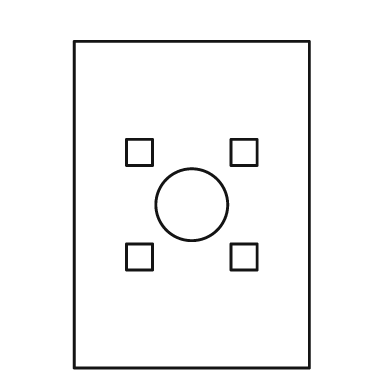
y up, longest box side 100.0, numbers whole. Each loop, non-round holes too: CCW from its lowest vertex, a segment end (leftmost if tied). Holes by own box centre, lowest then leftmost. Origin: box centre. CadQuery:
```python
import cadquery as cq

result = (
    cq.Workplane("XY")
    .moveTo(-36.0, -50.0)
    .lineTo(36.0, -50.0)
    .lineTo(36.0, 50.0)
    .lineTo(-36.0, 50.0)
    .close()
    .moveTo(-20.0, -20.0)
    .lineTo(-12.0, -20.0)
    .lineTo(-12.0, -12.0)
    .lineTo(-20.0, -12.0)
    .close()
    .moveTo(12.0, -20.0)
    .lineTo(20.0, -20.0)
    .lineTo(20.0, -12.0)
    .lineTo(12.0, -12.0)
    .close()
    .moveTo(0.0, 0.0)
    .circle(11.0)
    .moveTo(-20.0, 12.0)
    .lineTo(-12.0, 12.0)
    .lineTo(-12.0, 20.0)
    .lineTo(-20.0, 20.0)
    .close()
    .moveTo(12.0, 12.0)
    .lineTo(20.0, 12.0)
    .lineTo(20.0, 20.0)
    .lineTo(12.0, 20.0)
    .close()
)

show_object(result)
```